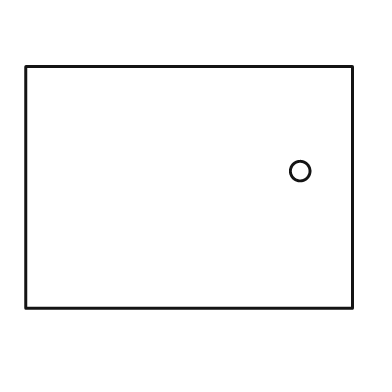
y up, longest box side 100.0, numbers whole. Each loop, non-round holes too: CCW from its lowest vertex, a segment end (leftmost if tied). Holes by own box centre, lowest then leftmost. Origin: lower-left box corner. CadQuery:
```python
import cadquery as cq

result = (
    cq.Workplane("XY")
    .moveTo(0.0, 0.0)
    .lineTo(100.0, 0.0)
    .lineTo(100.0, 74.0)
    .lineTo(0.0, 74.0)
    .close()
    .moveTo(84.0, 42.0)
    .circle(3.0)
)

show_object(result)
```